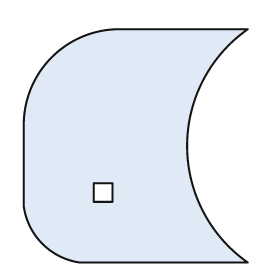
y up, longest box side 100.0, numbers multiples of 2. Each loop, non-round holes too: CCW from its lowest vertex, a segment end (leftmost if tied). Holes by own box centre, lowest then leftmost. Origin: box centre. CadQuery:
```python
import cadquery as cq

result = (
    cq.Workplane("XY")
    .moveTo(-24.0, -50.0)
    .lineTo(48.0, -50.0)
    .threePointArc((22.0, 0.0), (48.0, 50.0))
    .lineTo(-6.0, 50.0)
    .threePointArc((-36.0, 38.0), (-48.0, 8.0))
    .lineTo(-48.0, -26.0)
    .threePointArc((-40.0, -42.0), (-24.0, -50.0))
    .close()
    .moveTo(-18.0, -24.0)
    .lineTo(-10.0, -24.0)
    .lineTo(-10.0, -16.0)
    .lineTo(-18.0, -16.0)
    .close()
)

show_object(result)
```